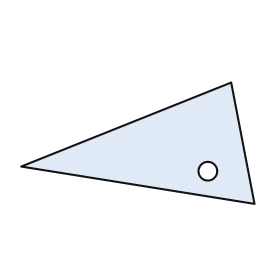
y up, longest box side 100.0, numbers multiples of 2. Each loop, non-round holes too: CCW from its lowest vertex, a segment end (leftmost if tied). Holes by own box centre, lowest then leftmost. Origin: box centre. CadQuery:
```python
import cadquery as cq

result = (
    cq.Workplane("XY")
    .moveTo(50.0, -26.0)
    .lineTo(40.0, 26.0)
    .lineTo(-50.0, -10.0)
    .close()
    .moveTo(30.0, -12.0)
    .circle(4.0)
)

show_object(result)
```